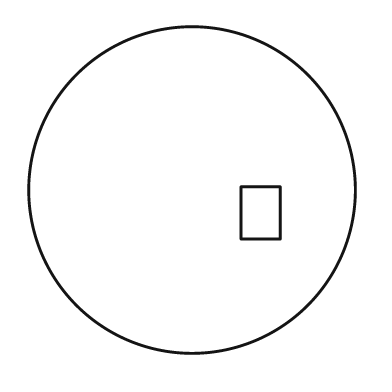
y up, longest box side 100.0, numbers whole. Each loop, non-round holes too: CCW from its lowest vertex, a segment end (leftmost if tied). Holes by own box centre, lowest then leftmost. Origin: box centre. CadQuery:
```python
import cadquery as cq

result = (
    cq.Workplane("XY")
    .moveTo(0.0, 0.0)
    .circle(50.0)
    .moveTo(15.0, -15.0)
    .lineTo(27.0, -15.0)
    .lineTo(27.0, 1.0)
    .lineTo(15.0, 1.0)
    .close()
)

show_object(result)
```